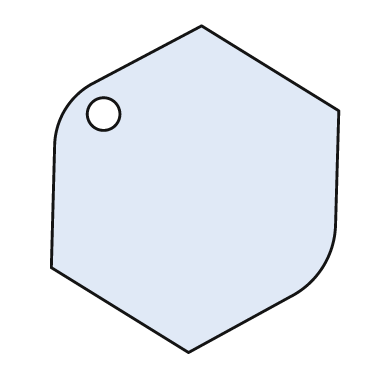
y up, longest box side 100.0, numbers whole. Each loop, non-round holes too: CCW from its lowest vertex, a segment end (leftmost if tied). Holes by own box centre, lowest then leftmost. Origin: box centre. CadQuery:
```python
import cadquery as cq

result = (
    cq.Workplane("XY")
    .moveTo(-2.0, -50.0)
    .lineTo(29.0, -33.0)
    .threePointArc((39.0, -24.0), (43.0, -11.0))
    .lineTo(44.0, 24.0)
    .lineTo(2.0, 50.0)
    .lineTo(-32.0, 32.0)
    .threePointArc((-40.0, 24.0), (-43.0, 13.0))
    .lineTo(-44.0, -24.0)
    .close()
    .moveTo(-28.0, 23.0)
    .circle(5.0)
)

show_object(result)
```